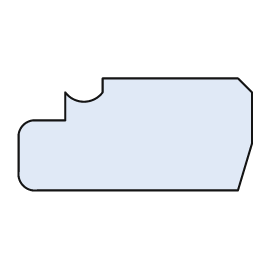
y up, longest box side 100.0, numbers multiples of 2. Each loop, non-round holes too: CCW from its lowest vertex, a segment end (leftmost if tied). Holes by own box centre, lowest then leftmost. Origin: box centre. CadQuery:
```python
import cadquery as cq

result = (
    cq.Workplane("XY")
    .moveTo(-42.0, -24.0)
    .lineTo(44.0, -24.0)
    .lineTo(50.0, -4.0)
    .lineTo(50.0, 18.0)
    .lineTo(44.0, 24.0)
    .lineTo(-14.0, 24.0)
    .lineTo(-14.0, 18.0)
    .threePointArc((-22.0, 14.0), (-30.0, 18.0))
    .lineTo(-30.0, 6.0)
    .lineTo(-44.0, 6.0)
    .threePointArc((-48.0, 4.0), (-50.0, 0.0))
    .lineTo(-50.0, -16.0)
    .threePointArc((-48.0, -22.0), (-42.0, -24.0))
    .close()
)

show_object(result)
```